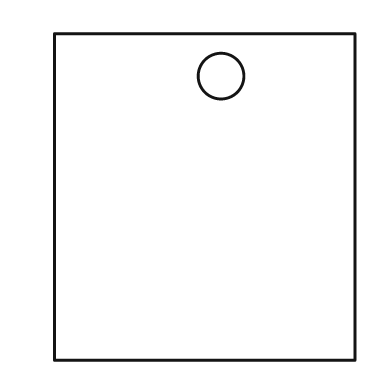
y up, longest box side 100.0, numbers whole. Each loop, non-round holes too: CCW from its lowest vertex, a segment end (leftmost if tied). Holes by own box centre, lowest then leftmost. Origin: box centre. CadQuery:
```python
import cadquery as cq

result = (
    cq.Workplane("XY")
    .moveTo(-46.0, -50.0)
    .lineTo(46.0, -50.0)
    .lineTo(46.0, 50.0)
    .lineTo(-46.0, 50.0)
    .close()
    .moveTo(5.0, 37.0)
    .circle(7.0)
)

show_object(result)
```